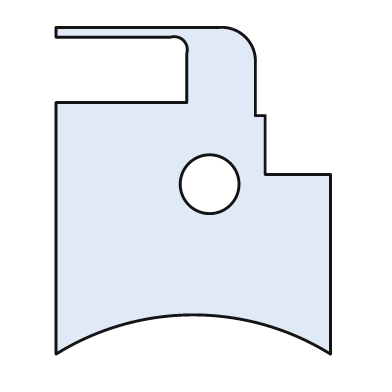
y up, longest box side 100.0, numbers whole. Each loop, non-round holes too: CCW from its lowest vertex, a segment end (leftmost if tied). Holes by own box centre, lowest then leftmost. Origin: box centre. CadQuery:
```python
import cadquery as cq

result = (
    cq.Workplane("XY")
    .moveTo(-42.0, -50.0)
    .threePointArc((0.0, -38.0), (42.0, -50.0))
    .lineTo(42.0, 5.0)
    .lineTo(22.0, 5.0)
    .lineTo(22.0, 23.0)
    .lineTo(19.0, 23.0)
    .lineTo(19.0, 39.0)
    .threePointArc((16.0, 47.0), (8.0, 50.0))
    .lineTo(-42.0, 50.0)
    .lineTo(-42.0, 47.0)
    .lineTo(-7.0, 47.0)
    .threePointArc((-3.0, 46.0), (-2.0, 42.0))
    .lineTo(-2.0, 27.0)
    .lineTo(-42.0, 27.0)
    .close()
    .moveTo(5.0, 2.0)
    .circle(9.0)
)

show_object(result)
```